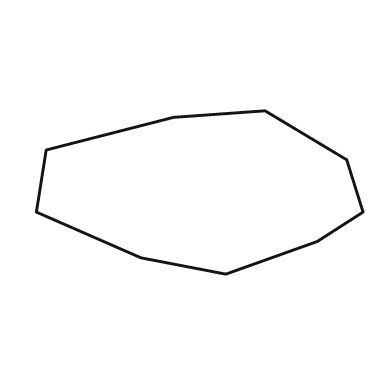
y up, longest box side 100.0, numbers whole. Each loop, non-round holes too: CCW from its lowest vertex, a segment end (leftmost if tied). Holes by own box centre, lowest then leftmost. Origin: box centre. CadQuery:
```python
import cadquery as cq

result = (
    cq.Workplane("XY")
    .moveTo(8.0, -25.0)
    .lineTo(36.0, -15.0)
    .lineTo(50.0, -6.0)
    .lineTo(45.0, 10.0)
    .lineTo(20.0, 25.0)
    .lineTo(-8.0, 23.0)
    .lineTo(-47.0, 13.0)
    .lineTo(-50.0, -6.0)
    .lineTo(-18.0, -20.0)
    .close()
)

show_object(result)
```